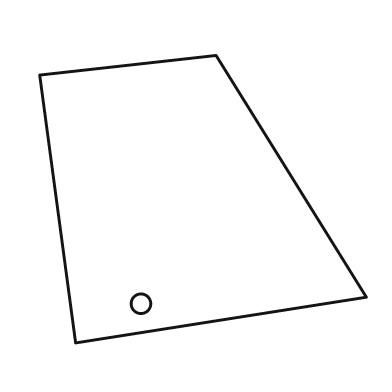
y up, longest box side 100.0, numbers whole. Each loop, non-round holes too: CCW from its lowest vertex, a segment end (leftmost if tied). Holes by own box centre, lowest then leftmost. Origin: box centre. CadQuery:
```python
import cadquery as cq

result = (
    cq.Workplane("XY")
    .moveTo(-39.0, -44.0)
    .lineTo(50.0, -30.0)
    .lineTo(4.0, 44.0)
    .lineTo(-50.0, 38.0)
    .close()
    .moveTo(-19.0, -32.0)
    .circle(3.0)
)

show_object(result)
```